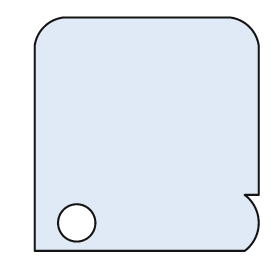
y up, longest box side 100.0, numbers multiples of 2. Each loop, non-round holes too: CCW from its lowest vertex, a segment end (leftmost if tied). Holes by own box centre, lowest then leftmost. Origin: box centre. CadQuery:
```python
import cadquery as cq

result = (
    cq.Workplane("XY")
    .moveTo(-48.0, -50.0)
    .lineTo(42.0, -50.0)
    .threePointArc((48.0, -38.0), (42.0, -26.0))
    .lineTo(48.0, -26.0)
    .lineTo(48.0, 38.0)
    .threePointArc((44.0, 46.0), (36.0, 50.0))
    .lineTo(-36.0, 50.0)
    .threePointArc((-44.0, 46.0), (-48.0, 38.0))
    .close()
    .moveTo(-30.0, -38.0)
    .circle(8.0)
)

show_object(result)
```